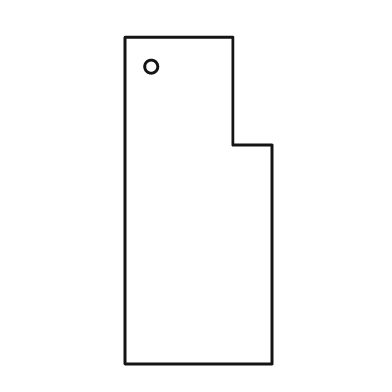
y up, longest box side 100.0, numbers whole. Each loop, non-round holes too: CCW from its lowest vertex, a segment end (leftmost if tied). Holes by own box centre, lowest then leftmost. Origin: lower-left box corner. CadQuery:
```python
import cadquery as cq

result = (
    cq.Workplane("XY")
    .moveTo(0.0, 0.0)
    .lineTo(45.0, 0.0)
    .lineTo(45.0, 67.0)
    .lineTo(33.0, 67.0)
    .lineTo(33.0, 100.0)
    .lineTo(0.0, 100.0)
    .close()
    .moveTo(8.0, 91.0)
    .circle(2.0)
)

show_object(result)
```